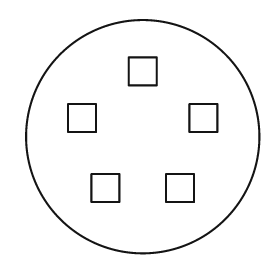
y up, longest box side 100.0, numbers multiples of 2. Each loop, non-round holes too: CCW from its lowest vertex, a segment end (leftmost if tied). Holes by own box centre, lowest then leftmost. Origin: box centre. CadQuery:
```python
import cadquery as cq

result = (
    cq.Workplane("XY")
    .moveTo(0.0, 0.0)
    .circle(50.0)
    .moveTo(-22.0, -28.0)
    .lineTo(-10.0, -28.0)
    .lineTo(-10.0, -16.0)
    .lineTo(-22.0, -16.0)
    .close()
    .moveTo(10.0, -28.0)
    .lineTo(22.0, -28.0)
    .lineTo(22.0, -16.0)
    .lineTo(10.0, -16.0)
    .close()
    .moveTo(-32.0, 2.0)
    .lineTo(-20.0, 2.0)
    .lineTo(-20.0, 14.0)
    .lineTo(-32.0, 14.0)
    .close()
    .moveTo(20.0, 2.0)
    .lineTo(32.0, 2.0)
    .lineTo(32.0, 14.0)
    .lineTo(20.0, 14.0)
    .close()
    .moveTo(-6.0, 22.0)
    .lineTo(6.0, 22.0)
    .lineTo(6.0, 34.0)
    .lineTo(-6.0, 34.0)
    .close()
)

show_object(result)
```